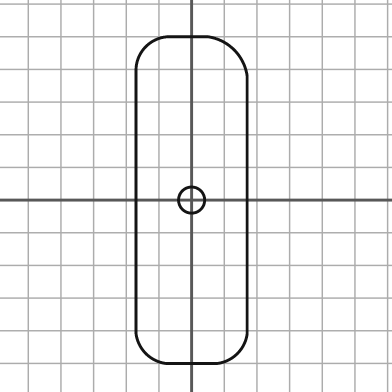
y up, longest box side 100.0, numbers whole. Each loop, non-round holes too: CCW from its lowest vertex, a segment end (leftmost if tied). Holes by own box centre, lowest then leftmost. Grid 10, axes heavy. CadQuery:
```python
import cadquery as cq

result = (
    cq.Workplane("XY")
    .moveTo(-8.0, -50.0)
    .lineTo(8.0, -50.0)
    .threePointArc((14.0, -47.0), (17.0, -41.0))
    .lineTo(17.0, 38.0)
    .threePointArc((13.0, 46.0), (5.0, 50.0))
    .lineTo(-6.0, 50.0)
    .threePointArc((-14.0, 47.0), (-17.0, 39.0))
    .lineTo(-17.0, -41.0)
    .threePointArc((-14.0, -47.0), (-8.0, -50.0))
    .close()
    .moveTo(0.0, 0.0)
    .circle(4.0)
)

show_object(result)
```